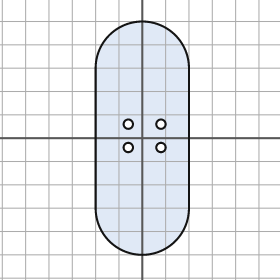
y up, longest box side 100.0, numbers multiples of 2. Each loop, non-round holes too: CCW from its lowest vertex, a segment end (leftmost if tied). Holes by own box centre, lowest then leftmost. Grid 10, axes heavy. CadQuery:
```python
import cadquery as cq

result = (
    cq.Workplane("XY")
    .moveTo(-20.0, -30.0)
    .threePointArc((0.0, -50.0), (20.0, -30.0))
    .lineTo(20.0, 30.0)
    .threePointArc((0.0, 50.0), (-20.0, 30.0))
    .close()
    .moveTo(-6.0, -4.0)
    .circle(2.0)
    .moveTo(8.0, -4.0)
    .circle(2.0)
    .moveTo(-6.0, 6.0)
    .circle(2.0)
    .moveTo(8.0, 6.0)
    .circle(2.0)
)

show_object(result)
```